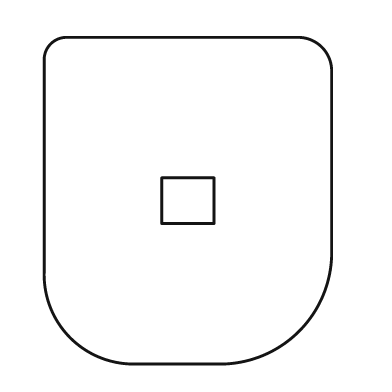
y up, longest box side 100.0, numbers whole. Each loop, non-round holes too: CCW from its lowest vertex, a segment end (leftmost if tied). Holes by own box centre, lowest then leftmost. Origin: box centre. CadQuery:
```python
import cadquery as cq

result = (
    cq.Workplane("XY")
    .moveTo(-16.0, -50.0)
    .lineTo(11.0, -50.0)
    .threePointArc((34.0, -40.0), (44.0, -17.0))
    .lineTo(44.0, 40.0)
    .threePointArc((41.0, 47.0), (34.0, 50.0))
    .lineTo(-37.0, 50.0)
    .threePointArc((-42.0, 48.0), (-44.0, 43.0))
    .lineTo(-44.0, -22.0)
    .threePointArc((-36.0, -42.0), (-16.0, -50.0))
    .close()
    .moveTo(-8.0, -7.0)
    .lineTo(8.0, -7.0)
    .lineTo(8.0, 7.0)
    .lineTo(-8.0, 7.0)
    .close()
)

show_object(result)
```